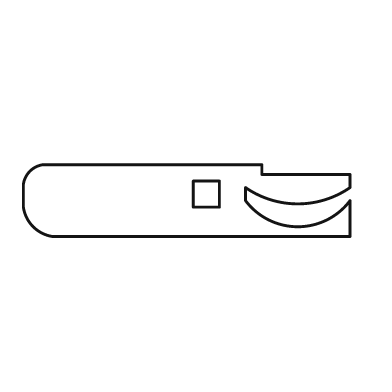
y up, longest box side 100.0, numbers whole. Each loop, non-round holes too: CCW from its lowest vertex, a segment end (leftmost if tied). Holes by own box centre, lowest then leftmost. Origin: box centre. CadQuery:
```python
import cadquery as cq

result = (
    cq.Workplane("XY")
    .moveTo(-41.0, -11.0)
    .lineTo(50.0, -11.0)
    .lineTo(50.0, 0.0)
    .threePointArc((34.0, -8.0), (18.0, 0.0))
    .lineTo(18.0, 4.0)
    .threePointArc((34.0, -1.0), (50.0, 4.0))
    .lineTo(50.0, 8.0)
    .lineTo(23.0, 8.0)
    .lineTo(23.0, 11.0)
    .lineTo(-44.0, 11.0)
    .threePointArc((-48.0, 9.0), (-50.0, 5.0))
    .lineTo(-50.0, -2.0)
    .threePointArc((-47.0, -8.0), (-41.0, -11.0))
    .close()
    .moveTo(2.0, -2.0)
    .lineTo(10.0, -2.0)
    .lineTo(10.0, 6.0)
    .lineTo(2.0, 6.0)
    .close()
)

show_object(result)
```